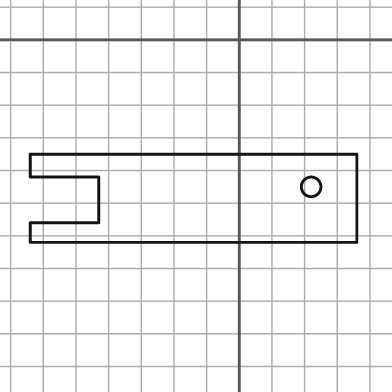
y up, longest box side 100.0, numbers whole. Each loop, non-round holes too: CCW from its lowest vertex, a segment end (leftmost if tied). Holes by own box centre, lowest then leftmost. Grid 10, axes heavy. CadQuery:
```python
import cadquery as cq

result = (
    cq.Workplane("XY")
    .moveTo(-64.0, -62.0)
    .lineTo(36.0, -62.0)
    .lineTo(36.0, -35.0)
    .lineTo(-64.0, -35.0)
    .lineTo(-64.0, -42.0)
    .lineTo(-43.0, -42.0)
    .lineTo(-43.0, -56.0)
    .lineTo(-64.0, -56.0)
    .close()
    .moveTo(22.0, -45.0)
    .circle(3.0)
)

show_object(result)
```